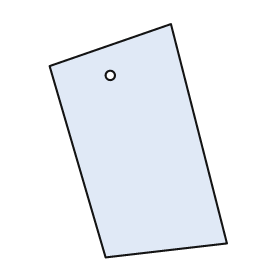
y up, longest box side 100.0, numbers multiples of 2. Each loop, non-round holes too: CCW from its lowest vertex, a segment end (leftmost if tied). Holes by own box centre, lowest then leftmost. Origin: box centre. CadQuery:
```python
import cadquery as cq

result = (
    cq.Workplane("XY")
    .moveTo(-14.0, -50.0)
    .lineTo(38.0, -44.0)
    .lineTo(14.0, 50.0)
    .lineTo(-38.0, 32.0)
    .close()
    .moveTo(-12.0, 28.0)
    .circle(2.0)
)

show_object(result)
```